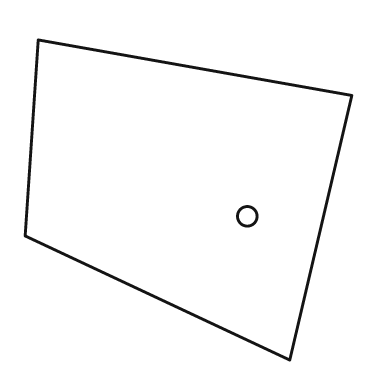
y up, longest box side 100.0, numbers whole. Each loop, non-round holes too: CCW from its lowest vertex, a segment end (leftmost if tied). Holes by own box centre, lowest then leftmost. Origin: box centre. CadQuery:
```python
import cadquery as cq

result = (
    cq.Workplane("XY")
    .moveTo(31.0, -49.0)
    .lineTo(50.0, 32.0)
    .lineTo(-46.0, 49.0)
    .lineTo(-50.0, -11.0)
    .close()
    .moveTo(18.0, -5.0)
    .circle(3.0)
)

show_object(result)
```